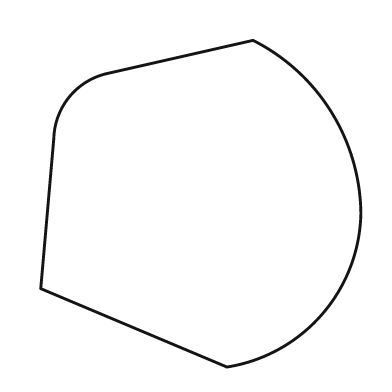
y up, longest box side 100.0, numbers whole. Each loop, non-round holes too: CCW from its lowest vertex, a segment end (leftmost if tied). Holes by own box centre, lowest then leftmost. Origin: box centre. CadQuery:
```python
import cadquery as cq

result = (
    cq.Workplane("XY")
    .moveTo(8.0, -50.0)
    .threePointArc((37.0, -34.0), (49.0, -3.0))
    .threePointArc((40.0, 28.0), (16.0, 50.0))
    .lineTo(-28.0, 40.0)
    .threePointArc((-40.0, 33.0), (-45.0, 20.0))
    .lineTo(-49.0, -26.0)
    .close()
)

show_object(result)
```